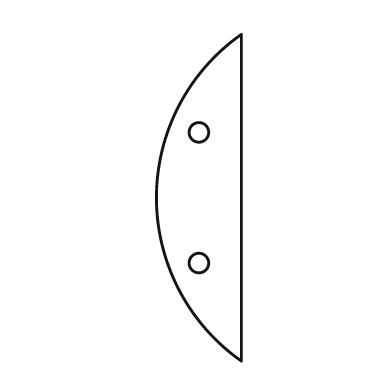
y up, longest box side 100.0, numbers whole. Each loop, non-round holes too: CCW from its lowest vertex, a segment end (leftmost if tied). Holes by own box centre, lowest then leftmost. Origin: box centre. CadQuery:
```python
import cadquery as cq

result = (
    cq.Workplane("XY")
    .moveTo(13.0, -50.0)
    .lineTo(13.0, 50.0)
    .threePointArc((-13.0, 0.0), (13.0, -50.0))
    .close()
    .moveTo(0.0, -20.0)
    .circle(3.0)
    .moveTo(0.0, 20.0)
    .circle(3.0)
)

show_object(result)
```